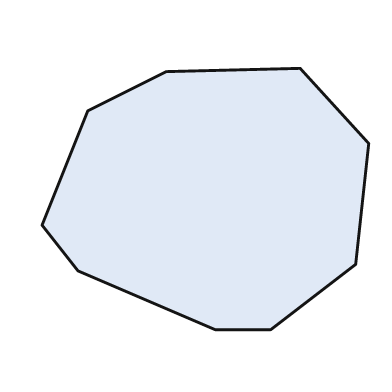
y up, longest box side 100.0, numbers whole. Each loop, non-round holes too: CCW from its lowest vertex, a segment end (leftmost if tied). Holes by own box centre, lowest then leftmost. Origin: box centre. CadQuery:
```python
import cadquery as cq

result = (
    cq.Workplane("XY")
    .moveTo(3.0, -40.0)
    .lineTo(20.0, -40.0)
    .lineTo(46.0, -20.0)
    .lineTo(50.0, 17.0)
    .lineTo(29.0, 40.0)
    .lineTo(-12.0, 39.0)
    .lineTo(-36.0, 27.0)
    .lineTo(-50.0, -8.0)
    .lineTo(-39.0, -22.0)
    .close()
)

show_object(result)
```